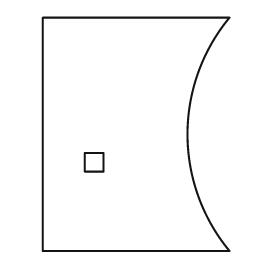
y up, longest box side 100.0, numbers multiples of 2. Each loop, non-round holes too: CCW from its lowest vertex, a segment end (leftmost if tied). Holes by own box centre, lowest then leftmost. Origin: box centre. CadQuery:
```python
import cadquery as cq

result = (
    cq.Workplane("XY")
    .moveTo(-40.0, -50.0)
    .lineTo(40.0, -50.0)
    .threePointArc((22.0, 0.0), (40.0, 50.0))
    .lineTo(-40.0, 50.0)
    .close()
    .moveTo(-22.0, -16.0)
    .lineTo(-14.0, -16.0)
    .lineTo(-14.0, -8.0)
    .lineTo(-22.0, -8.0)
    .close()
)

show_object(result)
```